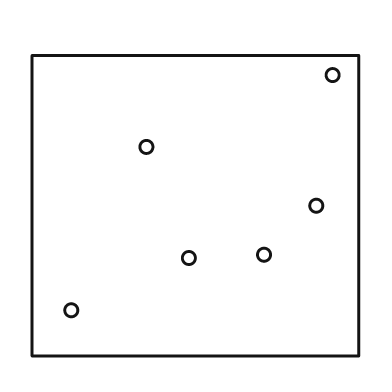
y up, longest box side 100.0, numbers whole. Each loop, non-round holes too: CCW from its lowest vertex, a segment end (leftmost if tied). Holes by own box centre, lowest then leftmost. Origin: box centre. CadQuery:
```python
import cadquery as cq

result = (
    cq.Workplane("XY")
    .moveTo(-50.0, -46.0)
    .lineTo(50.0, -46.0)
    .lineTo(50.0, 46.0)
    .lineTo(-50.0, 46.0)
    .close()
    .moveTo(-38.0, -32.0)
    .circle(2.0)
    .moveTo(-2.0, -16.0)
    .circle(2.0)
    .moveTo(21.0, -15.0)
    .circle(2.0)
    .moveTo(37.0, 0.0)
    .circle(2.0)
    .moveTo(-15.0, 18.0)
    .circle(2.0)
    .moveTo(42.0, 40.0)
    .circle(2.0)
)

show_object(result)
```